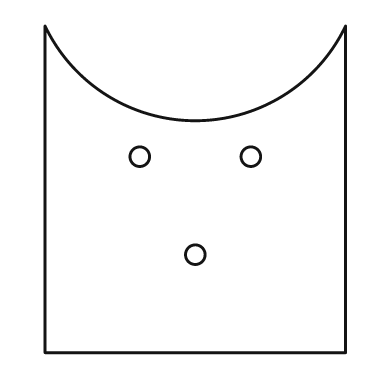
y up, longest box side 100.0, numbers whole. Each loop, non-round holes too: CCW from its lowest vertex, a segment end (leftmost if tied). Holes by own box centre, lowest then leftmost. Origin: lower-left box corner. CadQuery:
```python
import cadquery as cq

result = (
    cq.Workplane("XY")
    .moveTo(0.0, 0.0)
    .lineTo(92.0, 0.0)
    .lineTo(92.0, 100.0)
    .threePointArc((46.0, 71.0), (0.0, 100.0))
    .close()
    .moveTo(46.0, 30.0)
    .circle(3.0)
    .moveTo(29.0, 60.0)
    .circle(3.0)
    .moveTo(63.0, 60.0)
    .circle(3.0)
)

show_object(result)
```